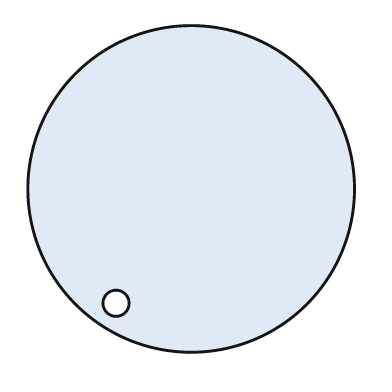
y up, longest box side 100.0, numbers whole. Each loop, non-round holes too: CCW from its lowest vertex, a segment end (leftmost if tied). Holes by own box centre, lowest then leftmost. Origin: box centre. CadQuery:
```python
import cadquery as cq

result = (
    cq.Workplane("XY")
    .moveTo(0.0, 0.0)
    .circle(50.0)
    .moveTo(-23.0, -35.0)
    .circle(4.0)
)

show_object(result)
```